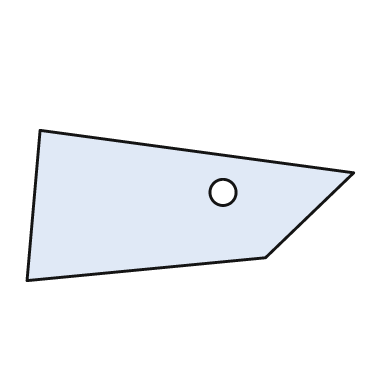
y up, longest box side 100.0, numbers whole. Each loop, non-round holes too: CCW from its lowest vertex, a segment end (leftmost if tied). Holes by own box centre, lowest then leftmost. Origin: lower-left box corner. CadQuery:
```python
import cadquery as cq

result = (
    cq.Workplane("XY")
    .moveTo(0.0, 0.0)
    .lineTo(73.0, 7.0)
    .lineTo(100.0, 33.0)
    .lineTo(4.0, 46.0)
    .close()
    .moveTo(60.0, 27.0)
    .circle(4.0)
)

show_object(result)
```